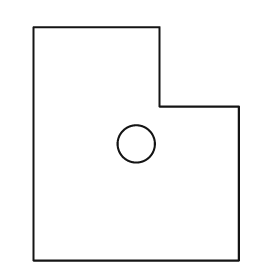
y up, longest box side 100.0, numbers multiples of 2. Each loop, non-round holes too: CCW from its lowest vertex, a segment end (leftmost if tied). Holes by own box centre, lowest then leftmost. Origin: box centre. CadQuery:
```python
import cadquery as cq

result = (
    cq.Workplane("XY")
    .moveTo(-44.0, -50.0)
    .lineTo(44.0, -50.0)
    .lineTo(44.0, 16.0)
    .lineTo(10.0, 16.0)
    .lineTo(10.0, 50.0)
    .lineTo(-44.0, 50.0)
    .close()
    .moveTo(0.0, 0.0)
    .circle(8.0)
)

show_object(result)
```